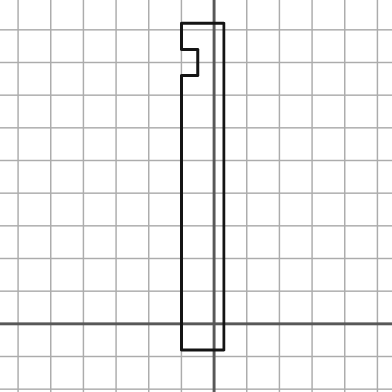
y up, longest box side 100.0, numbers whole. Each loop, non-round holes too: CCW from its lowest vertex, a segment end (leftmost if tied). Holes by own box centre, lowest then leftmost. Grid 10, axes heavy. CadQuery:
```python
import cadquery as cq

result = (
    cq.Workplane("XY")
    .moveTo(-10.0, -8.0)
    .lineTo(3.0, -8.0)
    .lineTo(3.0, 92.0)
    .lineTo(-10.0, 92.0)
    .lineTo(-10.0, 84.0)
    .lineTo(-5.0, 84.0)
    .lineTo(-5.0, 76.0)
    .lineTo(-10.0, 76.0)
    .close()
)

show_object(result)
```